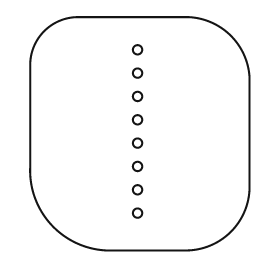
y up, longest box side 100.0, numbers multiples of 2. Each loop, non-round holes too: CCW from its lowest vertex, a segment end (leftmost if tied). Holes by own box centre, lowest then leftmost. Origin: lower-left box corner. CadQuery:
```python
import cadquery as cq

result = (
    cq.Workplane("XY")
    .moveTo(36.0, 0.0)
    .lineTo(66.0, 0.0)
    .threePointArc((86.0, 8.0), (94.0, 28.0))
    .lineTo(94.0, 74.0)
    .threePointArc((86.0, 92.0), (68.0, 100.0))
    .lineTo(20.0, 100.0)
    .threePointArc((6.0, 94.0), (0.0, 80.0))
    .lineTo(0.0, 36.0)
    .threePointArc((10.0, 10.0), (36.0, 0.0))
    .close()
    .moveTo(46.0, 16.0)
    .circle(2.0)
    .moveTo(46.0, 26.0)
    .circle(2.0)
    .moveTo(46.0, 36.0)
    .circle(2.0)
    .moveTo(46.0, 46.0)
    .circle(2.0)
    .moveTo(46.0, 56.0)
    .circle(2.0)
    .moveTo(46.0, 66.0)
    .circle(2.0)
    .moveTo(46.0, 76.0)
    .circle(2.0)
    .moveTo(46.0, 86.0)
    .circle(2.0)
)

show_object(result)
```